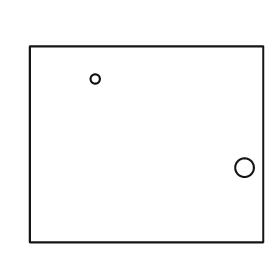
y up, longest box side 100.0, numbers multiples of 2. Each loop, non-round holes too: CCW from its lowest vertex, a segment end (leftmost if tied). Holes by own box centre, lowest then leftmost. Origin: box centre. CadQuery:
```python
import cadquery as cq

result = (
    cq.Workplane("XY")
    .moveTo(-50.0, -42.0)
    .lineTo(50.0, -42.0)
    .lineTo(50.0, 42.0)
    .lineTo(-50.0, 42.0)
    .close()
    .moveTo(42.0, -10.0)
    .circle(4.0)
    .moveTo(-22.0, 28.0)
    .circle(2.0)
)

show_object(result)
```